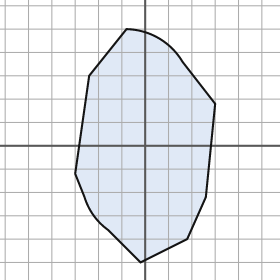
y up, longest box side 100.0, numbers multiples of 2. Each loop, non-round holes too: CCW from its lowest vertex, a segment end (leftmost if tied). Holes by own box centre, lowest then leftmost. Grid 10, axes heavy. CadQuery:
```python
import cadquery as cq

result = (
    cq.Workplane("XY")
    .moveTo(-2.0, -50.0)
    .lineTo(18.0, -40.0)
    .lineTo(26.0, -22.0)
    .lineTo(30.0, 18.0)
    .lineTo(16.0, 36.0)
    .threePointArc((6.0, 46.0), (-8.0, 50.0))
    .lineTo(-24.0, 30.0)
    .lineTo(-30.0, -12.0)
    .lineTo(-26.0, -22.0)
    .threePointArc((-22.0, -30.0), (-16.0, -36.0))
    .close()
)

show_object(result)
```